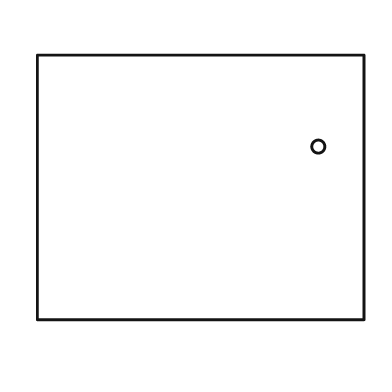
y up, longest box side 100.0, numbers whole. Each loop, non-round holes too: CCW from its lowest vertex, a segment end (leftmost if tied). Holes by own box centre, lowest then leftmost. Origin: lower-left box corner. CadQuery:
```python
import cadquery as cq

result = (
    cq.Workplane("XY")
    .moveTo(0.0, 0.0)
    .lineTo(100.0, 0.0)
    .lineTo(100.0, 81.0)
    .lineTo(0.0, 81.0)
    .close()
    .moveTo(86.0, 53.0)
    .circle(2.0)
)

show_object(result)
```